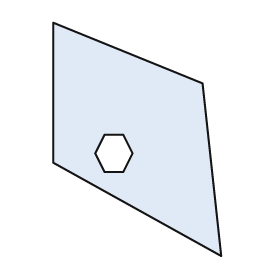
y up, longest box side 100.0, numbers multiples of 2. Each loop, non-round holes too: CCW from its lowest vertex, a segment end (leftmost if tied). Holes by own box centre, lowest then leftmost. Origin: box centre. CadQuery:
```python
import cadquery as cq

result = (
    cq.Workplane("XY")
    .moveTo(36.0, -50.0)
    .lineTo(28.0, 24.0)
    .lineTo(-36.0, 50.0)
    .lineTo(-36.0, -10.0)
    .close()
    .moveTo(-14.0, -14.0)
    .lineTo(-6.0, -14.0)
    .lineTo(-2.0, -6.0)
    .lineTo(-6.0, 2.0)
    .lineTo(-14.0, 2.0)
    .lineTo(-18.0, -6.0)
    .close()
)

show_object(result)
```